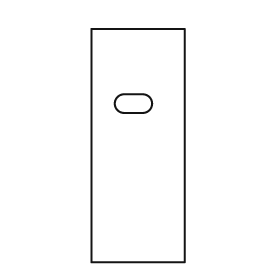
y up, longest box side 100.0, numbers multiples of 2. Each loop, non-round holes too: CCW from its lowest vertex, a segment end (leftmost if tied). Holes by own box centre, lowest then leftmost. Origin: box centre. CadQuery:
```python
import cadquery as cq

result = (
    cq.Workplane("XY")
    .moveTo(-20.0, -50.0)
    .lineTo(20.0, -50.0)
    .lineTo(20.0, 50.0)
    .lineTo(-20.0, 50.0)
    .close()
    .moveTo(-6.0, 14.0)
    .lineTo(2.0, 14.0)
    .threePointArc((6.0, 18.0), (2.0, 22.0))
    .lineTo(-6.0, 22.0)
    .threePointArc((-10.0, 18.0), (-6.0, 14.0))
    .close()
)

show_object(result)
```